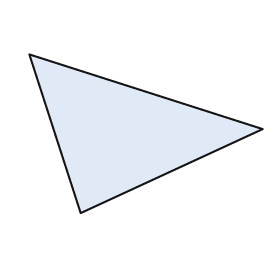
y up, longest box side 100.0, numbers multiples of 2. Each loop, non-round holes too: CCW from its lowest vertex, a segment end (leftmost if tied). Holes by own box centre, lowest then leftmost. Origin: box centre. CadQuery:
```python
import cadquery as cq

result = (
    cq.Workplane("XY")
    .moveTo(-28.0, -34.0)
    .lineTo(50.0, 2.0)
    .lineTo(-50.0, 34.0)
    .close()
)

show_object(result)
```